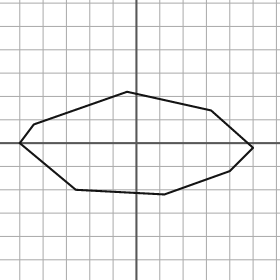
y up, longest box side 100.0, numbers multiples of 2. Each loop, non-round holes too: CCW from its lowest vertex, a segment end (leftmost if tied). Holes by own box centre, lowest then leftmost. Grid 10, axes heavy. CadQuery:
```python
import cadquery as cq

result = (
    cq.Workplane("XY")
    .moveTo(12.0, -22.0)
    .lineTo(40.0, -12.0)
    .lineTo(50.0, -2.0)
    .lineTo(32.0, 14.0)
    .lineTo(-4.0, 22.0)
    .lineTo(-44.0, 8.0)
    .lineTo(-50.0, 0.0)
    .lineTo(-26.0, -20.0)
    .close()
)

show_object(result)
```